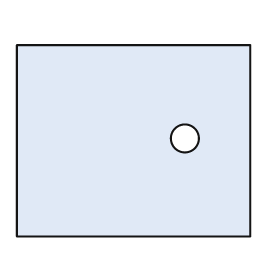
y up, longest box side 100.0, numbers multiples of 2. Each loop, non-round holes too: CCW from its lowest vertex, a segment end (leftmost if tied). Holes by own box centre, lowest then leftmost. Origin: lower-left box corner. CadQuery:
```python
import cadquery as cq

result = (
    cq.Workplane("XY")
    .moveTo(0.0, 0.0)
    .lineTo(100.0, 0.0)
    .lineTo(100.0, 82.0)
    .lineTo(0.0, 82.0)
    .close()
    .moveTo(72.0, 42.0)
    .circle(6.0)
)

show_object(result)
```